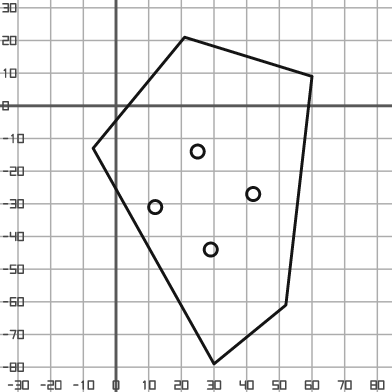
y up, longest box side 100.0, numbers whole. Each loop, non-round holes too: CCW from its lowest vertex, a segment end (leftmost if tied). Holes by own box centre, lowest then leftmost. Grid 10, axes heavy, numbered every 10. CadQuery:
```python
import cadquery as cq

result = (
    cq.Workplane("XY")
    .moveTo(30.0, -79.0)
    .lineTo(52.0, -61.0)
    .lineTo(60.0, 9.0)
    .lineTo(21.0, 21.0)
    .lineTo(-7.0, -13.0)
    .close()
    .moveTo(29.0, -44.0)
    .circle(2.0)
    .moveTo(12.0, -31.0)
    .circle(2.0)
    .moveTo(42.0, -27.0)
    .circle(2.0)
    .moveTo(25.0, -14.0)
    .circle(2.0)
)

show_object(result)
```